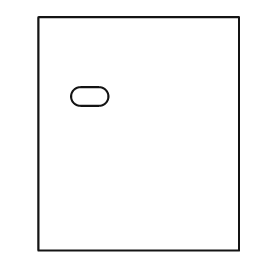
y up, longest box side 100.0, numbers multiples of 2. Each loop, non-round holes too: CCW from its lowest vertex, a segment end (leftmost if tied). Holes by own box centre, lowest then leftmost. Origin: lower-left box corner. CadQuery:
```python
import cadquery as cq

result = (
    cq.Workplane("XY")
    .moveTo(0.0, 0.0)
    .lineTo(86.0, 0.0)
    .lineTo(86.0, 100.0)
    .lineTo(0.0, 100.0)
    .close()
    .moveTo(18.0, 62.0)
    .lineTo(26.0, 62.0)
    .threePointArc((30.0, 66.0), (26.0, 70.0))
    .lineTo(18.0, 70.0)
    .threePointArc((14.0, 66.0), (18.0, 62.0))
    .close()
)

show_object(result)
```